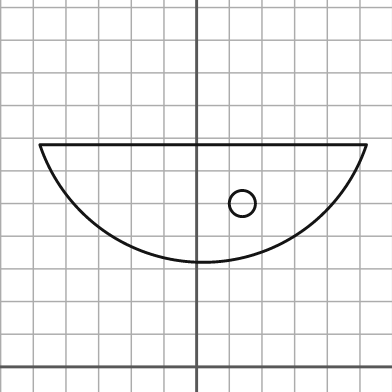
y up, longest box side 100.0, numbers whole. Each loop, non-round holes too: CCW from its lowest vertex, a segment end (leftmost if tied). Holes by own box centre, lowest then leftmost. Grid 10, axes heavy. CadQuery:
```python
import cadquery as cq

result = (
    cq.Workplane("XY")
    .moveTo(-48.0, 68.0)
    .threePointArc((2.0, 32.0), (52.0, 68.0))
    .close()
    .moveTo(14.0, 50.0)
    .circle(4.0)
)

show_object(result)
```